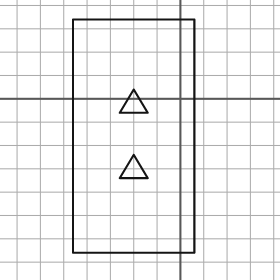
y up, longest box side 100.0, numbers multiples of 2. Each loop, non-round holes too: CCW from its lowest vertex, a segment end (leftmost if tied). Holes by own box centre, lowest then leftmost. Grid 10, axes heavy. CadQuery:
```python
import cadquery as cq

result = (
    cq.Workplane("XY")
    .moveTo(-46.0, -66.0)
    .lineTo(6.0, -66.0)
    .lineTo(6.0, 34.0)
    .lineTo(-46.0, 34.0)
    .close()
    .moveTo(-26.0, -34.0)
    .lineTo(-14.0, -34.0)
    .lineTo(-20.0, -24.0)
    .close()
    .moveTo(-26.0, -6.0)
    .lineTo(-14.0, -6.0)
    .lineTo(-20.0, 4.0)
    .close()
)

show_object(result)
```